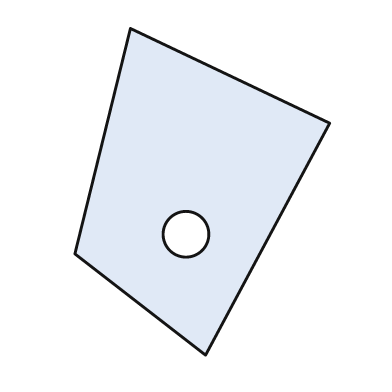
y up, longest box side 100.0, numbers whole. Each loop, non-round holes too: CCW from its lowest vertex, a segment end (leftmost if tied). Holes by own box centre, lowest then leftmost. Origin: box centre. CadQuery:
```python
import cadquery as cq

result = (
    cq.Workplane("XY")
    .moveTo(1.0, -50.0)
    .lineTo(39.0, 21.0)
    .lineTo(-22.0, 50.0)
    .lineTo(-39.0, -19.0)
    .close()
    .moveTo(-5.0, -13.0)
    .circle(7.0)
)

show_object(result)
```